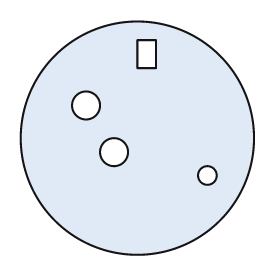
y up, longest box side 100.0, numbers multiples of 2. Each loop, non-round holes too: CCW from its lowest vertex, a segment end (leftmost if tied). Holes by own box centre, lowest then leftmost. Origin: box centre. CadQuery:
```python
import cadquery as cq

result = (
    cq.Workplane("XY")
    .moveTo(0.0, 0.0)
    .circle(50.0)
    .moveTo(30.0, -16.0)
    .circle(4.0)
    .moveTo(-10.0, -6.0)
    .circle(6.0)
    .moveTo(-22.0, 14.0)
    .circle(6.0)
    .moveTo(0.0, 30.0)
    .lineTo(8.0, 30.0)
    .lineTo(8.0, 42.0)
    .lineTo(0.0, 42.0)
    .close()
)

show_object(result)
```